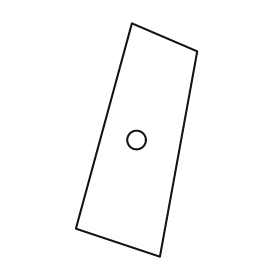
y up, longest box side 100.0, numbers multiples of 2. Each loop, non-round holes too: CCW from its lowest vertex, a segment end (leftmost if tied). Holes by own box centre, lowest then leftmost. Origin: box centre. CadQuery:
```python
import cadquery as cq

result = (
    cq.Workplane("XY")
    .moveTo(10.0, -50.0)
    .lineTo(26.0, 38.0)
    .lineTo(-2.0, 50.0)
    .lineTo(-26.0, -38.0)
    .close()
    .moveTo(0.0, 0.0)
    .circle(4.0)
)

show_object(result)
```